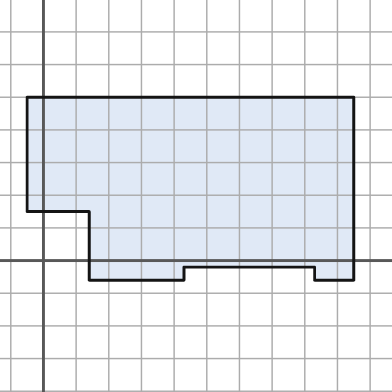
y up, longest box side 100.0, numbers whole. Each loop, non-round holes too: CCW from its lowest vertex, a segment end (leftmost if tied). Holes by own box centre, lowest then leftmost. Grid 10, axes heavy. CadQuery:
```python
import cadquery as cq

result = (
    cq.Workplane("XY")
    .moveTo(14.0, -6.0)
    .lineTo(43.0, -6.0)
    .lineTo(43.0, -2.0)
    .lineTo(83.0, -2.0)
    .lineTo(83.0, -6.0)
    .lineTo(95.0, -6.0)
    .lineTo(95.0, 50.0)
    .lineTo(-5.0, 50.0)
    .lineTo(-5.0, 15.0)
    .lineTo(14.0, 15.0)
    .close()
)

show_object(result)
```